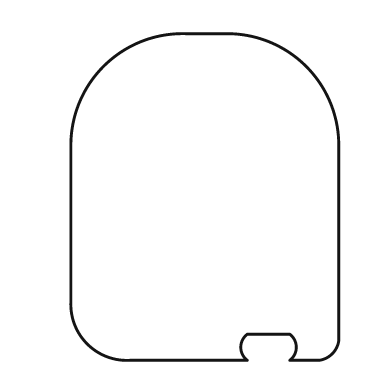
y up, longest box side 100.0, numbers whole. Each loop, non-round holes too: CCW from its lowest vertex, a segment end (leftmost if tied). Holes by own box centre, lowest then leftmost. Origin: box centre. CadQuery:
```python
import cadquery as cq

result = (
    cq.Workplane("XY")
    .moveTo(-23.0, -50.0)
    .lineTo(13.0, -50.0)
    .threePointArc((11.0, -46.0), (13.0, -42.0))
    .lineTo(26.0, -42.0)
    .threePointArc((28.0, -46.0), (26.0, -50.0))
    .lineTo(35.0, -50.0)
    .threePointArc((39.0, -48.0), (41.0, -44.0))
    .lineTo(41.0, 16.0)
    .threePointArc((31.0, 40.0), (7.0, 50.0))
    .lineTo(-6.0, 50.0)
    .threePointArc((-31.0, 40.0), (-41.0, 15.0))
    .lineTo(-41.0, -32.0)
    .threePointArc((-36.0, -45.0), (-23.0, -50.0))
    .close()
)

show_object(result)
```